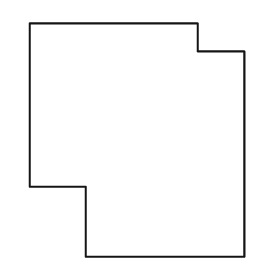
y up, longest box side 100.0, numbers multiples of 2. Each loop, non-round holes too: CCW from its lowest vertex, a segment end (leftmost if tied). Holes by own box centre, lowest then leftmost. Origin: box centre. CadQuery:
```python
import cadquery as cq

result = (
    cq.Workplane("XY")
    .moveTo(-22.0, -50.0)
    .lineTo(46.0, -50.0)
    .lineTo(46.0, 38.0)
    .lineTo(26.0, 38.0)
    .lineTo(26.0, 50.0)
    .lineTo(-46.0, 50.0)
    .lineTo(-46.0, -20.0)
    .lineTo(-22.0, -20.0)
    .close()
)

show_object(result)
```